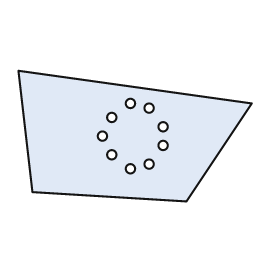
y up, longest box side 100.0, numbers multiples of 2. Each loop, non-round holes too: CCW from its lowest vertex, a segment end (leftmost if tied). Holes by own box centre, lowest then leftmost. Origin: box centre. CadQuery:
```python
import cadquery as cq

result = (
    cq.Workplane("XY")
    .moveTo(22.0, -28.0)
    .lineTo(50.0, 14.0)
    .lineTo(-50.0, 28.0)
    .lineTo(-44.0, -24.0)
    .close()
    .moveTo(-2.0, -14.0)
    .circle(2.0)
    .moveTo(6.0, -12.0)
    .circle(2.0)
    .moveTo(-10.0, -8.0)
    .circle(2.0)
    .moveTo(12.0, -4.0)
    .circle(2.0)
    .moveTo(-14.0, 0.0)
    .circle(2.0)
    .moveTo(12.0, 4.0)
    .circle(2.0)
    .moveTo(-10.0, 8.0)
    .circle(2.0)
    .moveTo(6.0, 12.0)
    .circle(2.0)
    .moveTo(-2.0, 14.0)
    .circle(2.0)
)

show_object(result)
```